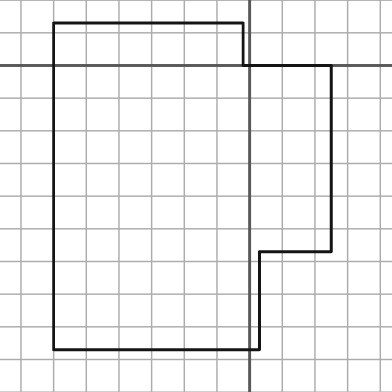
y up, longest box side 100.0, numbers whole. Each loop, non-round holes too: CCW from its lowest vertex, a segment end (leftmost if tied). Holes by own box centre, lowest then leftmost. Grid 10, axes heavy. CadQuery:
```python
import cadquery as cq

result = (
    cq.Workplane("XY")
    .moveTo(-60.0, -87.0)
    .lineTo(3.0, -87.0)
    .lineTo(3.0, -57.0)
    .lineTo(25.0, -57.0)
    .lineTo(25.0, 0.0)
    .lineTo(-2.0, 0.0)
    .lineTo(-2.0, 13.0)
    .lineTo(-60.0, 13.0)
    .close()
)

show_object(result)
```